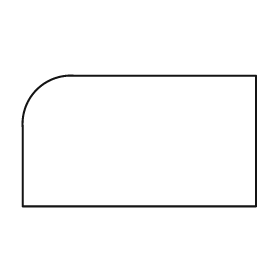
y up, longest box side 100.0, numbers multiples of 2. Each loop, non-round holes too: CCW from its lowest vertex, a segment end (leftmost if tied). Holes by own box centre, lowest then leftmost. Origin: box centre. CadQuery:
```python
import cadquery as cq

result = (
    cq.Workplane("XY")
    .moveTo(-50.0, -28.0)
    .lineTo(50.0, -28.0)
    .lineTo(50.0, 28.0)
    .lineTo(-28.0, 28.0)
    .threePointArc((-44.0, 22.0), (-50.0, 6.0))
    .close()
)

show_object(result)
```